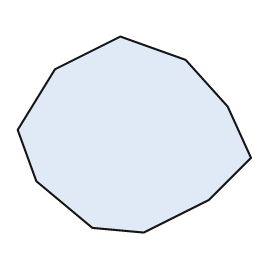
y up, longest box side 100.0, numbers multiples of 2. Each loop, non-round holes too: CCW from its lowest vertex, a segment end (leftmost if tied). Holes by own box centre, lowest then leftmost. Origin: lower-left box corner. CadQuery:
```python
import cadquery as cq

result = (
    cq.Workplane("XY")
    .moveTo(54.0, 0.0)
    .lineTo(82.0, 14.0)
    .lineTo(100.0, 32.0)
    .lineTo(90.0, 54.0)
    .lineTo(72.0, 74.0)
    .lineTo(44.0, 84.0)
    .lineTo(16.0, 70.0)
    .lineTo(0.0, 44.0)
    .lineTo(8.0, 22.0)
    .lineTo(32.0, 2.0)
    .close()
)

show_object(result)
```